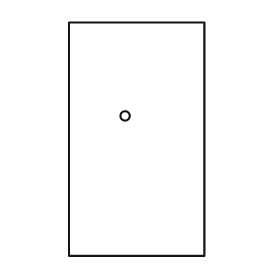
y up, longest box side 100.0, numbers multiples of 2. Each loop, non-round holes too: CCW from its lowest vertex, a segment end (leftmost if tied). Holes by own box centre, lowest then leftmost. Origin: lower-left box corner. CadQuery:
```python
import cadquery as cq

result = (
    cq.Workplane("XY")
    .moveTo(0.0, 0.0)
    .lineTo(58.0, 0.0)
    .lineTo(58.0, 100.0)
    .lineTo(0.0, 100.0)
    .close()
    .moveTo(24.0, 60.0)
    .circle(2.0)
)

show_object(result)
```